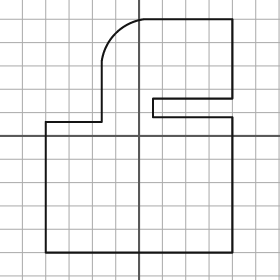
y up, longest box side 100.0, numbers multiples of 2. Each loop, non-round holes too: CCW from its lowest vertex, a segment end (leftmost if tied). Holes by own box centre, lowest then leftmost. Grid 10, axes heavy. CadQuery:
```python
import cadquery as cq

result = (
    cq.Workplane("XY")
    .moveTo(-40.0, -50.0)
    .lineTo(40.0, -50.0)
    .lineTo(40.0, 8.0)
    .lineTo(6.0, 8.0)
    .lineTo(6.0, 16.0)
    .lineTo(40.0, 16.0)
    .lineTo(40.0, 50.0)
    .lineTo(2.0, 50.0)
    .threePointArc((-10.0, 44.0), (-16.0, 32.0))
    .lineTo(-16.0, 6.0)
    .lineTo(-40.0, 6.0)
    .close()
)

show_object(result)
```